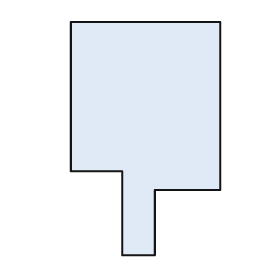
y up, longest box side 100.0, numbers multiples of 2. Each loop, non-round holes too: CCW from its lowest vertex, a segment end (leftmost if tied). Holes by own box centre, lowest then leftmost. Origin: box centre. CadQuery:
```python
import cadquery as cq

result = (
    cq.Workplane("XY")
    .moveTo(-10.0, -50.0)
    .lineTo(4.0, -50.0)
    .lineTo(4.0, -22.0)
    .lineTo(32.0, -22.0)
    .lineTo(32.0, 50.0)
    .lineTo(-32.0, 50.0)
    .lineTo(-32.0, -14.0)
    .lineTo(-10.0, -14.0)
    .close()
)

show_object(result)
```